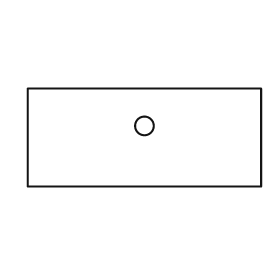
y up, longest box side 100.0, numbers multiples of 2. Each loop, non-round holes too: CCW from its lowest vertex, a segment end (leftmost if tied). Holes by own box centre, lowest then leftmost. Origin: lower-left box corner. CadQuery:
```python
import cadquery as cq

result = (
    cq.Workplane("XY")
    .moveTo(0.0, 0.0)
    .lineTo(100.0, 0.0)
    .lineTo(100.0, 42.0)
    .lineTo(0.0, 42.0)
    .close()
    .moveTo(50.0, 26.0)
    .circle(4.0)
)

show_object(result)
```